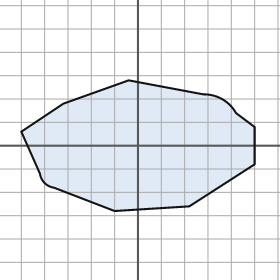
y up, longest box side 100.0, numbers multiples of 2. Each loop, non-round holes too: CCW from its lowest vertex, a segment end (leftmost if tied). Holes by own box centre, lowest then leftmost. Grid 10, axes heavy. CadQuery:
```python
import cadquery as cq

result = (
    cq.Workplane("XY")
    .moveTo(-10.0, -28.0)
    .lineTo(22.0, -26.0)
    .lineTo(50.0, -8.0)
    .lineTo(50.0, 8.0)
    .lineTo(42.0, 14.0)
    .threePointArc((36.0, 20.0), (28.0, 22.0))
    .lineTo(-4.0, 28.0)
    .lineTo(-32.0, 18.0)
    .lineTo(-50.0, 6.0)
    .lineTo(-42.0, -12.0)
    .threePointArc((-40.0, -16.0), (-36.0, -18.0))
    .close()
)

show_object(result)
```